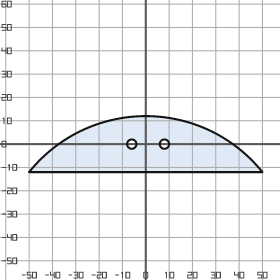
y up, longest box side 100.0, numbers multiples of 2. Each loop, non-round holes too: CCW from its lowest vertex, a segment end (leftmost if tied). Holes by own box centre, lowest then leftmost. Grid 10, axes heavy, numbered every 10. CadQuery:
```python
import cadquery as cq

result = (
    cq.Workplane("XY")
    .moveTo(-50.0, -12.0)
    .lineTo(50.0, -12.0)
    .threePointArc((0.0, 12.0), (-50.0, -12.0))
    .close()
    .moveTo(-6.0, 0.0)
    .circle(2.0)
    .moveTo(8.0, 0.0)
    .circle(2.0)
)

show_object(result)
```